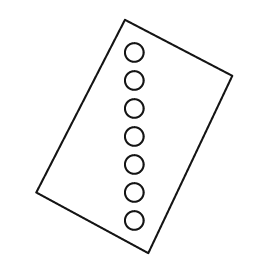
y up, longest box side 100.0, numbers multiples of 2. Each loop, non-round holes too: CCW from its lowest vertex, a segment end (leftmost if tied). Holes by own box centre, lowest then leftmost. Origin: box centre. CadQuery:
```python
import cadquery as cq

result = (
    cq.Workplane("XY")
    .moveTo(6.0, -50.0)
    .lineTo(42.0, 26.0)
    .lineTo(-4.0, 50.0)
    .lineTo(-42.0, -24.0)
    .close()
    .moveTo(0.0, -36.0)
    .circle(4.0)
    .moveTo(0.0, -24.0)
    .circle(4.0)
    .moveTo(0.0, -12.0)
    .circle(4.0)
    .moveTo(0.0, 0.0)
    .circle(4.0)
    .moveTo(0.0, 12.0)
    .circle(4.0)
    .moveTo(0.0, 24.0)
    .circle(4.0)
    .moveTo(0.0, 36.0)
    .circle(4.0)
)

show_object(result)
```